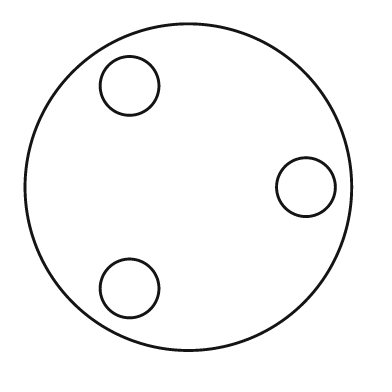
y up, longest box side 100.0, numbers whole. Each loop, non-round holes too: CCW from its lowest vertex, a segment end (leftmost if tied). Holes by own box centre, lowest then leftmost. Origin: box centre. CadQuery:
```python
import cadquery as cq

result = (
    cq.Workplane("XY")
    .moveTo(0.0, 0.0)
    .circle(50.0)
    .moveTo(-18.0, -31.0)
    .circle(9.0)
    .moveTo(36.0, 0.0)
    .circle(9.0)
    .moveTo(-18.0, 31.0)
    .circle(9.0)
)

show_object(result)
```